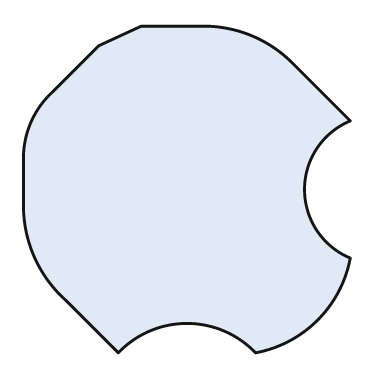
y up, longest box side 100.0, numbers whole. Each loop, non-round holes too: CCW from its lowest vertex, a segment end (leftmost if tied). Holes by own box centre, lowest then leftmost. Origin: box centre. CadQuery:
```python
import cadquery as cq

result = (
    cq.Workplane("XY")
    .moveTo(-21.0, -50.0)
    .threePointArc((0.0, -41.0), (21.0, -50.0))
    .threePointArc((40.0, -40.0), (50.0, -21.0))
    .threePointArc((36.0, 0.0), (50.0, 21.0))
    .lineTo(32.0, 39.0)
    .threePointArc((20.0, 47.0), (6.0, 50.0))
    .lineTo(-14.0, 50.0)
    .lineTo(-27.0, 44.0)
    .lineTo(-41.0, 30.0)
    .threePointArc((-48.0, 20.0), (-50.0, 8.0))
    .lineTo(-50.0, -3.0)
    .threePointArc((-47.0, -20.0), (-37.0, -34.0))
    .close()
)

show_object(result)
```